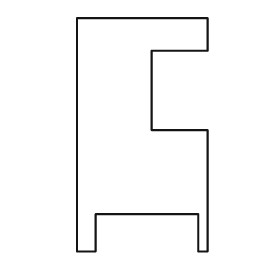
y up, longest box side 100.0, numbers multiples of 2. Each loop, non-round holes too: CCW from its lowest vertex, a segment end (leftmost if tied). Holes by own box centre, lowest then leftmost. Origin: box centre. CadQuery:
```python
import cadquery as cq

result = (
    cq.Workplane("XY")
    .moveTo(-28.0, -50.0)
    .lineTo(-20.0, -50.0)
    .lineTo(-20.0, -34.0)
    .lineTo(24.0, -34.0)
    .lineTo(24.0, -50.0)
    .lineTo(28.0, -50.0)
    .lineTo(28.0, 2.0)
    .lineTo(4.0, 2.0)
    .lineTo(4.0, 36.0)
    .lineTo(28.0, 36.0)
    .lineTo(28.0, 50.0)
    .lineTo(-28.0, 50.0)
    .close()
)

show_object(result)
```